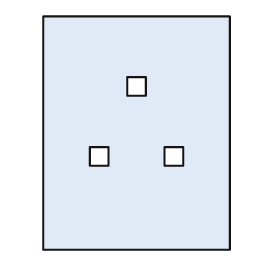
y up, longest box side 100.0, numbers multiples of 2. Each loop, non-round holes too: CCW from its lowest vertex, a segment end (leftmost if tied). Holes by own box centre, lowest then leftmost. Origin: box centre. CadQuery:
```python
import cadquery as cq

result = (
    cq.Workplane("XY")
    .moveTo(-40.0, -50.0)
    .lineTo(40.0, -50.0)
    .lineTo(40.0, 50.0)
    .lineTo(-40.0, 50.0)
    .close()
    .moveTo(-20.0, -14.0)
    .lineTo(-12.0, -14.0)
    .lineTo(-12.0, -6.0)
    .lineTo(-20.0, -6.0)
    .close()
    .moveTo(12.0, -14.0)
    .lineTo(20.0, -14.0)
    .lineTo(20.0, -6.0)
    .lineTo(12.0, -6.0)
    .close()
    .moveTo(-4.0, 16.0)
    .lineTo(4.0, 16.0)
    .lineTo(4.0, 24.0)
    .lineTo(-4.0, 24.0)
    .close()
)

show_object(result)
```